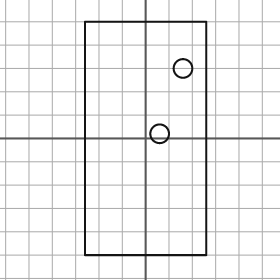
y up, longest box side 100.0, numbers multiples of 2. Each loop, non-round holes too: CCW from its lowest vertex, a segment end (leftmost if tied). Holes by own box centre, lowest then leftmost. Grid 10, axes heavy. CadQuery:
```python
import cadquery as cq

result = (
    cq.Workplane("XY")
    .moveTo(-26.0, -50.0)
    .lineTo(26.0, -50.0)
    .lineTo(26.0, 50.0)
    .lineTo(-26.0, 50.0)
    .close()
    .moveTo(6.0, 2.0)
    .circle(4.0)
    .moveTo(16.0, 30.0)
    .circle(4.0)
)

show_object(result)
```